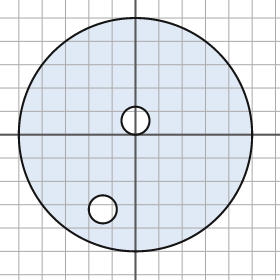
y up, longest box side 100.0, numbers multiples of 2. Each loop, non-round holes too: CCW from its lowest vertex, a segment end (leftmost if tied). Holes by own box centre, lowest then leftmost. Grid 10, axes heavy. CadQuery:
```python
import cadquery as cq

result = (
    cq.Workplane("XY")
    .moveTo(0.0, 0.0)
    .circle(50.0)
    .moveTo(-14.0, -32.0)
    .circle(6.0)
    .moveTo(0.0, 6.0)
    .circle(6.0)
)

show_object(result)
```